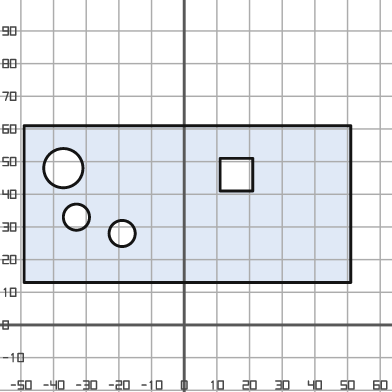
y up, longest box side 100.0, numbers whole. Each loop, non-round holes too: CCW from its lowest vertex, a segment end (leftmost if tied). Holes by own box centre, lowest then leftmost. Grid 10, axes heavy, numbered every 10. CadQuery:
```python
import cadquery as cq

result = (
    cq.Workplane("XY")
    .moveTo(-49.0, 13.0)
    .lineTo(51.0, 13.0)
    .lineTo(51.0, 61.0)
    .lineTo(-49.0, 61.0)
    .close()
    .moveTo(-19.0, 28.0)
    .circle(4.0)
    .moveTo(-33.0, 33.0)
    .circle(4.0)
    .moveTo(11.0, 41.0)
    .lineTo(21.0, 41.0)
    .lineTo(21.0, 51.0)
    .lineTo(11.0, 51.0)
    .close()
    .moveTo(-37.0, 48.0)
    .circle(6.0)
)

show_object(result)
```